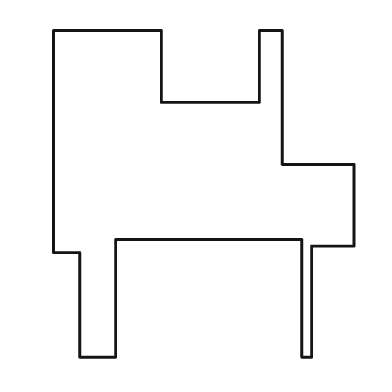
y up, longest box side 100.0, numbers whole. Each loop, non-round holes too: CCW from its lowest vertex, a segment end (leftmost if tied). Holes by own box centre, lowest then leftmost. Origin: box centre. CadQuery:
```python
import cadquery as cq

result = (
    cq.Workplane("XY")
    .moveTo(-38.0, -50.0)
    .lineTo(-27.0, -50.0)
    .lineTo(-27.0, -14.0)
    .lineTo(30.0, -14.0)
    .lineTo(30.0, -50.0)
    .lineTo(33.0, -50.0)
    .lineTo(33.0, -16.0)
    .lineTo(46.0, -16.0)
    .lineTo(46.0, 9.0)
    .lineTo(24.0, 9.0)
    .lineTo(24.0, 50.0)
    .lineTo(17.0, 50.0)
    .lineTo(17.0, 28.0)
    .lineTo(-13.0, 28.0)
    .lineTo(-13.0, 50.0)
    .lineTo(-46.0, 50.0)
    .lineTo(-46.0, -18.0)
    .lineTo(-38.0, -18.0)
    .close()
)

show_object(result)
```